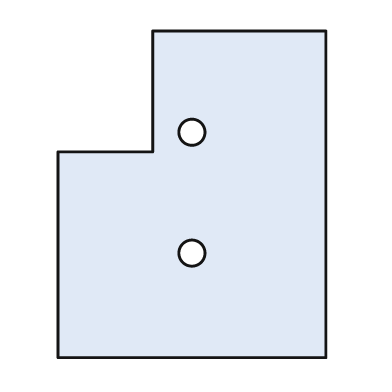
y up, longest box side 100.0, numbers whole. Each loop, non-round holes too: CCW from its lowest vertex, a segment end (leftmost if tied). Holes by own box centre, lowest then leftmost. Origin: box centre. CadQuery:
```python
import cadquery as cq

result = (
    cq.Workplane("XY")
    .moveTo(-41.0, -50.0)
    .lineTo(41.0, -50.0)
    .lineTo(41.0, 50.0)
    .lineTo(-12.0, 50.0)
    .lineTo(-12.0, 13.0)
    .lineTo(-41.0, 13.0)
    .close()
    .moveTo(0.0, -18.0)
    .circle(4.0)
    .moveTo(0.0, 19.0)
    .circle(4.0)
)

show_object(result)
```